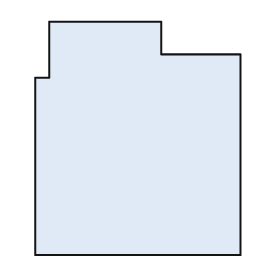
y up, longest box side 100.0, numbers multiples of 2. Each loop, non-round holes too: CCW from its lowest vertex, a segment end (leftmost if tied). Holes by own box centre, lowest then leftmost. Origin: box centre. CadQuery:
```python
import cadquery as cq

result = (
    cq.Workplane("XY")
    .moveTo(-44.0, -50.0)
    .lineTo(44.0, -50.0)
    .lineTo(44.0, 36.0)
    .lineTo(10.0, 36.0)
    .lineTo(10.0, 50.0)
    .lineTo(-38.0, 50.0)
    .lineTo(-38.0, 26.0)
    .lineTo(-44.0, 26.0)
    .close()
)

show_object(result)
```